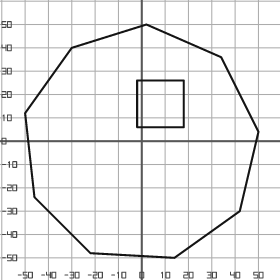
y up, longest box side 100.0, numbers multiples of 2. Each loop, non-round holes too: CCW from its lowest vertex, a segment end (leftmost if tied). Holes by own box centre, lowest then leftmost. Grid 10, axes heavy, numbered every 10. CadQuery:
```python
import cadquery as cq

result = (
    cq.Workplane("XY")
    .moveTo(14.0, -50.0)
    .lineTo(42.0, -30.0)
    .lineTo(50.0, 4.0)
    .lineTo(34.0, 36.0)
    .lineTo(2.0, 50.0)
    .lineTo(-30.0, 40.0)
    .lineTo(-50.0, 12.0)
    .lineTo(-46.0, -24.0)
    .lineTo(-22.0, -48.0)
    .close()
    .moveTo(-2.0, 6.0)
    .lineTo(18.0, 6.0)
    .lineTo(18.0, 26.0)
    .lineTo(-2.0, 26.0)
    .close()
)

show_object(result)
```